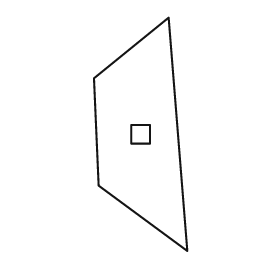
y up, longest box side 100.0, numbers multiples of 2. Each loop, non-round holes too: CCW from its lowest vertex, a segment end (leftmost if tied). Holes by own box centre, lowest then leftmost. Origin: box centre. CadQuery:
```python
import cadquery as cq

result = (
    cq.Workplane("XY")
    .moveTo(20.0, -50.0)
    .lineTo(12.0, 50.0)
    .lineTo(-20.0, 24.0)
    .lineTo(-18.0, -22.0)
    .close()
    .moveTo(-4.0, -4.0)
    .lineTo(4.0, -4.0)
    .lineTo(4.0, 4.0)
    .lineTo(-4.0, 4.0)
    .close()
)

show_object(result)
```